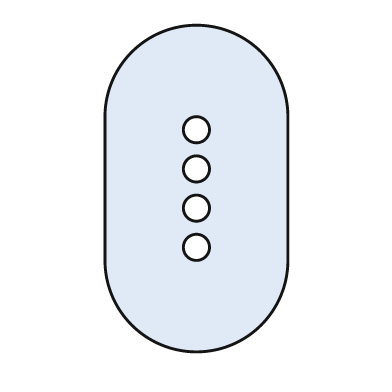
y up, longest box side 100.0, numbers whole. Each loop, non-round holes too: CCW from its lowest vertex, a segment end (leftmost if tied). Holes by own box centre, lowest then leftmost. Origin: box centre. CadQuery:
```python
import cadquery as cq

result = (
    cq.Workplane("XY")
    .moveTo(-28.0, -22.0)
    .threePointArc((0.0, -50.0), (28.0, -22.0))
    .lineTo(28.0, 22.0)
    .threePointArc((0.0, 50.0), (-28.0, 22.0))
    .close()
    .moveTo(0.0, -18.0)
    .circle(4.0)
    .moveTo(0.0, -6.0)
    .circle(4.0)
    .moveTo(0.0, 6.0)
    .circle(4.0)
    .moveTo(0.0, 18.0)
    .circle(4.0)
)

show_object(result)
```